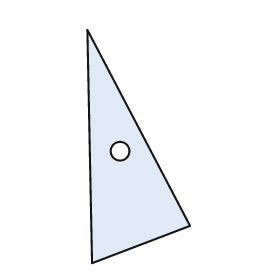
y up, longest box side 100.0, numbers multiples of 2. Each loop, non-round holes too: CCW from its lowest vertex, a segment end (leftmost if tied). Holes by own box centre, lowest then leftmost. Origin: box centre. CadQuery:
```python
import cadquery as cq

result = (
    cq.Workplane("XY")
    .moveTo(-20.0, -50.0)
    .lineTo(22.0, -34.0)
    .lineTo(-22.0, 50.0)
    .close()
    .moveTo(-8.0, -2.0)
    .circle(4.0)
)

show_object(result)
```